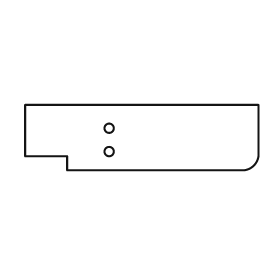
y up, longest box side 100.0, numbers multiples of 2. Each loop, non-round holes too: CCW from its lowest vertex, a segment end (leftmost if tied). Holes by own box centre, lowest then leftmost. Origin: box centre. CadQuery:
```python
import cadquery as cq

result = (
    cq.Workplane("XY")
    .moveTo(-32.0, -14.0)
    .lineTo(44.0, -14.0)
    .threePointArc((48.0, -12.0), (50.0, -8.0))
    .lineTo(50.0, 14.0)
    .lineTo(-50.0, 14.0)
    .lineTo(-50.0, -8.0)
    .lineTo(-32.0, -8.0)
    .close()
    .moveTo(-14.0, -6.0)
    .circle(2.0)
    .moveTo(-14.0, 4.0)
    .circle(2.0)
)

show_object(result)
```